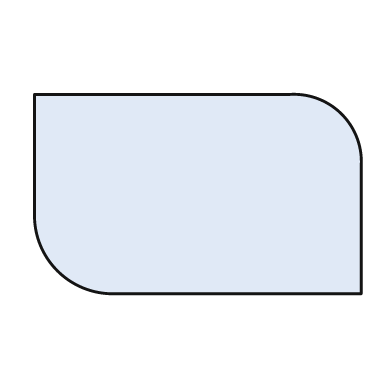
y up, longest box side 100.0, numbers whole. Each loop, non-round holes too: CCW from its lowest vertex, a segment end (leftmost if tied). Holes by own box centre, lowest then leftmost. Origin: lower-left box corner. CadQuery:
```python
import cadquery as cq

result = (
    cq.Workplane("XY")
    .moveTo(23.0, 0.0)
    .lineTo(100.0, 0.0)
    .lineTo(100.0, 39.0)
    .threePointArc((94.0, 55.0), (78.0, 61.0))
    .lineTo(0.0, 61.0)
    .lineTo(0.0, 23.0)
    .threePointArc((7.0, 7.0), (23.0, 0.0))
    .close()
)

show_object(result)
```